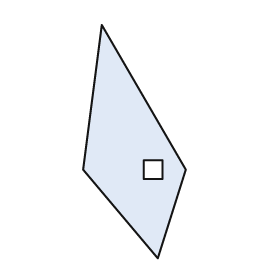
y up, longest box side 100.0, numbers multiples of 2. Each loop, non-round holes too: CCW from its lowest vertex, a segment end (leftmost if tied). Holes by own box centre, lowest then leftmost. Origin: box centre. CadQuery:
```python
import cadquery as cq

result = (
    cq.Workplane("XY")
    .moveTo(10.0, -50.0)
    .lineTo(22.0, -12.0)
    .lineTo(-14.0, 50.0)
    .lineTo(-22.0, -12.0)
    .close()
    .moveTo(4.0, -16.0)
    .lineTo(12.0, -16.0)
    .lineTo(12.0, -8.0)
    .lineTo(4.0, -8.0)
    .close()
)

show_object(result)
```